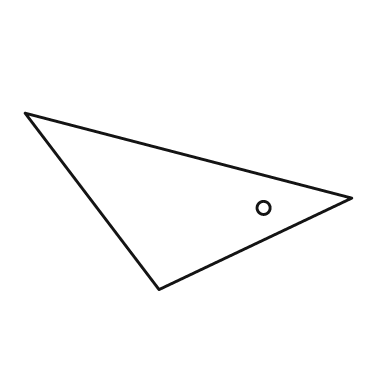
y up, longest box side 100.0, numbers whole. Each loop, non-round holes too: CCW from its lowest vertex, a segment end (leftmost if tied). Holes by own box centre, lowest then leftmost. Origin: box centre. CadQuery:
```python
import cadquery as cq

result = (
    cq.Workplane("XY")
    .moveTo(-9.0, -27.0)
    .lineTo(50.0, 1.0)
    .lineTo(-50.0, 27.0)
    .close()
    .moveTo(23.0, -2.0)
    .circle(2.0)
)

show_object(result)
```